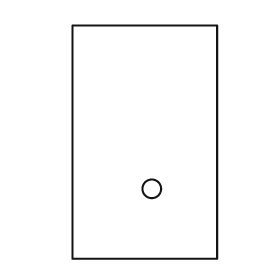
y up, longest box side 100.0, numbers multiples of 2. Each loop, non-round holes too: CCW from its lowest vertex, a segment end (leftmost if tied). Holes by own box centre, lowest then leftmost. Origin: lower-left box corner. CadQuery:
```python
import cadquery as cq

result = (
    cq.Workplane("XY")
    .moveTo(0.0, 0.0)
    .lineTo(62.0, 0.0)
    .lineTo(62.0, 100.0)
    .lineTo(0.0, 100.0)
    .close()
    .moveTo(34.0, 30.0)
    .circle(4.0)
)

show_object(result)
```